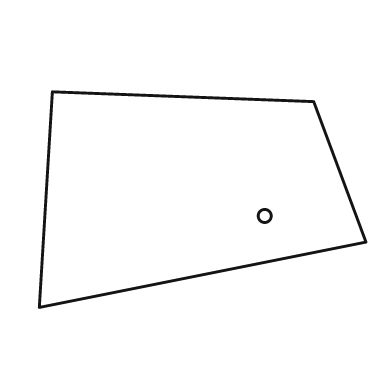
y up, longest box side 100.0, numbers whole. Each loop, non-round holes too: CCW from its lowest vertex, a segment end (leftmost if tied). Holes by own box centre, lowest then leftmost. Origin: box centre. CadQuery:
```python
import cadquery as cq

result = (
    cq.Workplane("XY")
    .moveTo(-50.0, -33.0)
    .lineTo(50.0, -13.0)
    .lineTo(34.0, 30.0)
    .lineTo(-46.0, 33.0)
    .close()
    .moveTo(19.0, -5.0)
    .circle(2.0)
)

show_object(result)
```